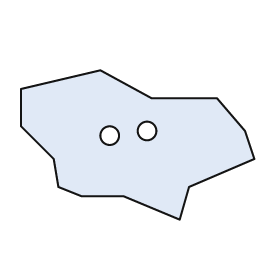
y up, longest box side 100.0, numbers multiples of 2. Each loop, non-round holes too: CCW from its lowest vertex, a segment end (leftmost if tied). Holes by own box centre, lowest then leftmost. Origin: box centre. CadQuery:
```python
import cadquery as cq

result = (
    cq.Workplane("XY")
    .moveTo(18.0, -32.0)
    .lineTo(22.0, -18.0)
    .lineTo(50.0, -6.0)
    .lineTo(46.0, 6.0)
    .lineTo(34.0, 20.0)
    .lineTo(6.0, 20.0)
    .lineTo(-16.0, 32.0)
    .lineTo(-50.0, 24.0)
    .lineTo(-50.0, 8.0)
    .lineTo(-36.0, -6.0)
    .lineTo(-34.0, -18.0)
    .lineTo(-24.0, -22.0)
    .lineTo(-6.0, -22.0)
    .close()
    .moveTo(-12.0, 4.0)
    .circle(4.0)
    .moveTo(4.0, 6.0)
    .circle(4.0)
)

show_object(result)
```